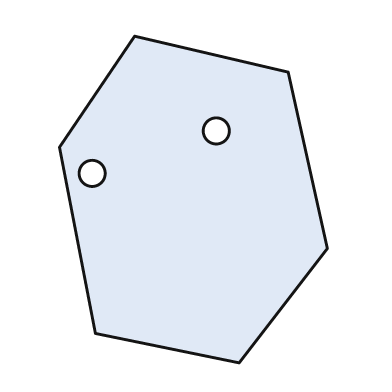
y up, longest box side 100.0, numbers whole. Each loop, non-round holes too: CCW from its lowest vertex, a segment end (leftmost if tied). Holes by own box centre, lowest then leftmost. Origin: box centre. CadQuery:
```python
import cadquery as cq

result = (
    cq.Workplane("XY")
    .moveTo(14.0, -50.0)
    .lineTo(41.0, -15.0)
    .lineTo(29.0, 39.0)
    .lineTo(-18.0, 50.0)
    .lineTo(-41.0, 16.0)
    .lineTo(-30.0, -41.0)
    .close()
    .moveTo(-31.0, 8.0)
    .circle(4.0)
    .moveTo(7.0, 21.0)
    .circle(4.0)
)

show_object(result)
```